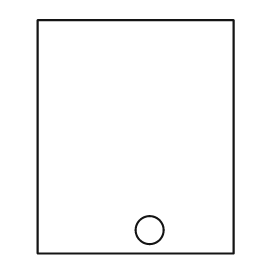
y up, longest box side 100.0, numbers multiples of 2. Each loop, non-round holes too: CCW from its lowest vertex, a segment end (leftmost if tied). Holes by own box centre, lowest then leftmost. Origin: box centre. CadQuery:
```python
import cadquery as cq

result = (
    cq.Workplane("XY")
    .moveTo(-42.0, -50.0)
    .lineTo(42.0, -50.0)
    .lineTo(42.0, 50.0)
    .lineTo(-42.0, 50.0)
    .close()
    .moveTo(6.0, -40.0)
    .circle(6.0)
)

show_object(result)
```